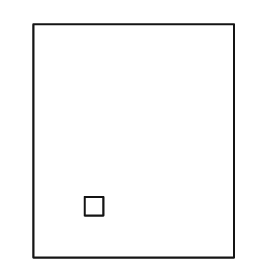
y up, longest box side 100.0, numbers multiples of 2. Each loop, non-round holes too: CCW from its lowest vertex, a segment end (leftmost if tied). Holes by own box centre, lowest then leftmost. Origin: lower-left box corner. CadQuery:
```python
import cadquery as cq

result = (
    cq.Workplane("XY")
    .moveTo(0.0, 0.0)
    .lineTo(86.0, 0.0)
    .lineTo(86.0, 100.0)
    .lineTo(0.0, 100.0)
    .close()
    .moveTo(22.0, 18.0)
    .lineTo(30.0, 18.0)
    .lineTo(30.0, 26.0)
    .lineTo(22.0, 26.0)
    .close()
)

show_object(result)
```